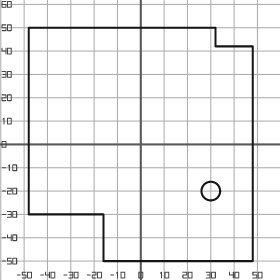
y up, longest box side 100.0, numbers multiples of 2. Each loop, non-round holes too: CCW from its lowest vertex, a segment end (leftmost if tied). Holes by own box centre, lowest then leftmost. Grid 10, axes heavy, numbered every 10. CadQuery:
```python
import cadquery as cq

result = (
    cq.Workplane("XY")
    .moveTo(-16.0, -50.0)
    .lineTo(48.0, -50.0)
    .lineTo(48.0, 42.0)
    .lineTo(32.0, 42.0)
    .lineTo(32.0, 50.0)
    .lineTo(-48.0, 50.0)
    .lineTo(-48.0, -30.0)
    .lineTo(-16.0, -30.0)
    .close()
    .moveTo(30.0, -20.0)
    .circle(4.0)
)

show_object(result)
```